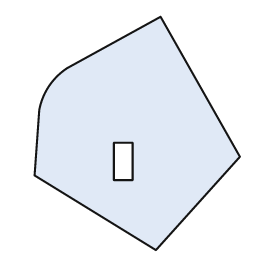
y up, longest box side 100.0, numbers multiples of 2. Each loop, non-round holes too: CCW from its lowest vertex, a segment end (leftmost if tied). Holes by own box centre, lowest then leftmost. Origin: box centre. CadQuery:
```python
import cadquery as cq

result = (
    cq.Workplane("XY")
    .moveTo(8.0, -50.0)
    .lineTo(44.0, -10.0)
    .lineTo(10.0, 50.0)
    .lineTo(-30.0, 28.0)
    .threePointArc((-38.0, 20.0), (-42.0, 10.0))
    .lineTo(-44.0, -18.0)
    .close()
    .moveTo(-10.0, -20.0)
    .lineTo(-2.0, -20.0)
    .lineTo(-2.0, -4.0)
    .lineTo(-10.0, -4.0)
    .close()
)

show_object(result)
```